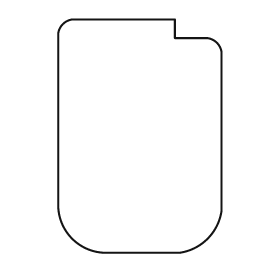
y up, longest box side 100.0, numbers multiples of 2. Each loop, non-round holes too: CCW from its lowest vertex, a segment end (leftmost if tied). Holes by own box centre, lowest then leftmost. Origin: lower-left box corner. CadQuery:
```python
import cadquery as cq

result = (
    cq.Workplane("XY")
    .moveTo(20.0, 0.0)
    .lineTo(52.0, 0.0)
    .threePointArc((64.0, 6.0), (70.0, 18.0))
    .lineTo(70.0, 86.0)
    .threePointArc((68.0, 90.0), (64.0, 92.0))
    .lineTo(50.0, 92.0)
    .lineTo(50.0, 100.0)
    .lineTo(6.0, 100.0)
    .threePointArc((2.0, 98.0), (0.0, 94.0))
    .lineTo(0.0, 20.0)
    .threePointArc((6.0, 6.0), (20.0, 0.0))
    .close()
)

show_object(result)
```